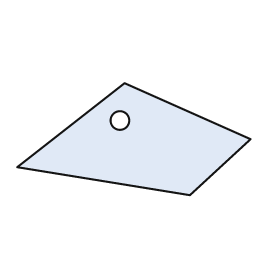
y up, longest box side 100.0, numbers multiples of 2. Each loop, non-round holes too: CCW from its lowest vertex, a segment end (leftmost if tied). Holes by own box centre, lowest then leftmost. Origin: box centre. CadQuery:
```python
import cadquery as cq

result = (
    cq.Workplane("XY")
    .moveTo(24.0, -24.0)
    .lineTo(50.0, 0.0)
    .lineTo(-4.0, 24.0)
    .lineTo(-50.0, -12.0)
    .close()
    .moveTo(-6.0, 8.0)
    .circle(4.0)
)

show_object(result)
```